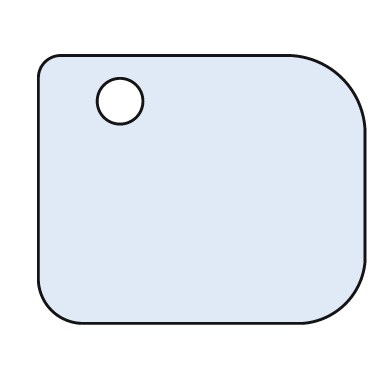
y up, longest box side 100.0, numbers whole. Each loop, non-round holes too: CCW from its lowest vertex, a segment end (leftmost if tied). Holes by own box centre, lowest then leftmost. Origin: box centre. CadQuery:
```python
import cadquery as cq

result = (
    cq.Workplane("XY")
    .moveTo(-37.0, -41.0)
    .lineTo(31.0, -41.0)
    .threePointArc((44.0, -35.0), (50.0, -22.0))
    .lineTo(50.0, 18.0)
    .threePointArc((43.0, 34.0), (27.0, 41.0))
    .lineTo(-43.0, 41.0)
    .threePointArc((-48.0, 39.0), (-50.0, 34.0))
    .lineTo(-50.0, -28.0)
    .threePointArc((-46.0, -37.0), (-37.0, -41.0))
    .close()
    .moveTo(-25.0, 27.0)
    .circle(7.0)
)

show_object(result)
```